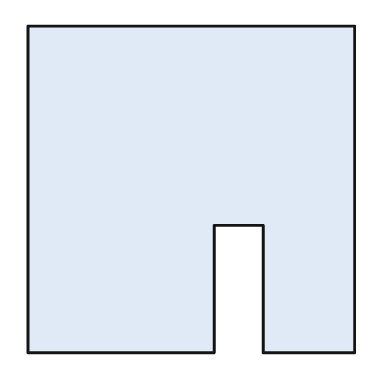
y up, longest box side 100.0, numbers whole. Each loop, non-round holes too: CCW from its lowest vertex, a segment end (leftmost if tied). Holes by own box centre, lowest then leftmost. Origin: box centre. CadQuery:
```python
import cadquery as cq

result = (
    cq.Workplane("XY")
    .moveTo(-50.0, -50.0)
    .lineTo(7.0, -50.0)
    .lineTo(7.0, -11.0)
    .lineTo(22.0, -11.0)
    .lineTo(22.0, -50.0)
    .lineTo(50.0, -50.0)
    .lineTo(50.0, 50.0)
    .lineTo(-50.0, 50.0)
    .close()
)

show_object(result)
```